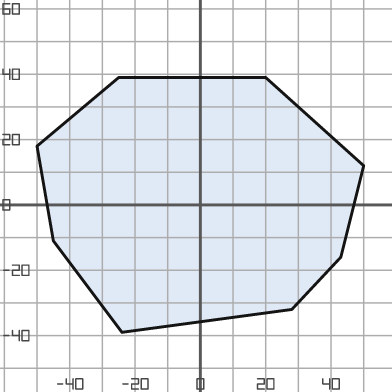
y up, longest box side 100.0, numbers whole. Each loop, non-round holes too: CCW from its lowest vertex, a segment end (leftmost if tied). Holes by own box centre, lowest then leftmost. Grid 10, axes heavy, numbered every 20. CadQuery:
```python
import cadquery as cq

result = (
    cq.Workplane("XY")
    .moveTo(-24.0, -39.0)
    .lineTo(28.0, -32.0)
    .lineTo(43.0, -16.0)
    .lineTo(50.0, 12.0)
    .lineTo(20.0, 39.0)
    .lineTo(-25.0, 39.0)
    .lineTo(-50.0, 18.0)
    .lineTo(-45.0, -11.0)
    .close()
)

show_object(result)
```